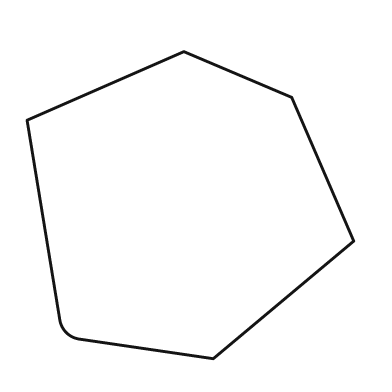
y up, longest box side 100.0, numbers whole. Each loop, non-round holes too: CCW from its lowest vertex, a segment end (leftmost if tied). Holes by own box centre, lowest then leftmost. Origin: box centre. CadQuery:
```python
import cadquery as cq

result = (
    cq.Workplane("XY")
    .moveTo(7.0, -47.0)
    .lineTo(50.0, -11.0)
    .lineTo(31.0, 33.0)
    .lineTo(-2.0, 47.0)
    .lineTo(-50.0, 26.0)
    .lineTo(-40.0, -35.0)
    .threePointArc((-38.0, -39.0), (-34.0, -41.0))
    .close()
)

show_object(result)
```